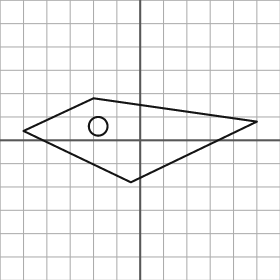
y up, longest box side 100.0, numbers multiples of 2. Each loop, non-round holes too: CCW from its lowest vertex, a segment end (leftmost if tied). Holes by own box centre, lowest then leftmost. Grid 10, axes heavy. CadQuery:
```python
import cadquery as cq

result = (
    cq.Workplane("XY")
    .moveTo(-4.0, -18.0)
    .lineTo(50.0, 8.0)
    .lineTo(-20.0, 18.0)
    .lineTo(-50.0, 4.0)
    .close()
    .moveTo(-18.0, 6.0)
    .circle(4.0)
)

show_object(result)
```